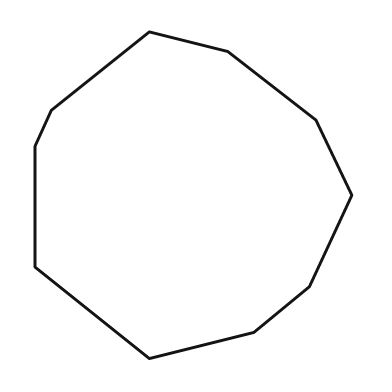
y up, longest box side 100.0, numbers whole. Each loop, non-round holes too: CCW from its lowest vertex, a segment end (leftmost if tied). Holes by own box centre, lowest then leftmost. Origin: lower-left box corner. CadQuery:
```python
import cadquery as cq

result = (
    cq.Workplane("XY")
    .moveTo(35.0, 0.0)
    .lineTo(67.0, 8.0)
    .lineTo(84.0, 22.0)
    .lineTo(97.0, 50.0)
    .lineTo(86.0, 73.0)
    .lineTo(59.0, 94.0)
    .lineTo(35.0, 100.0)
    .lineTo(5.0, 76.0)
    .lineTo(0.0, 65.0)
    .lineTo(0.0, 28.0)
    .close()
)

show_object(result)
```